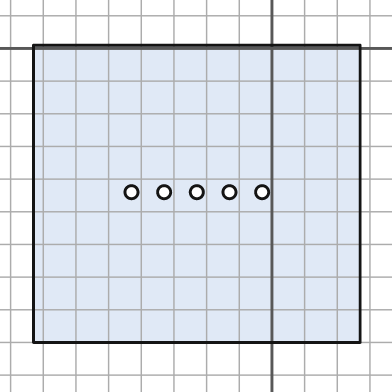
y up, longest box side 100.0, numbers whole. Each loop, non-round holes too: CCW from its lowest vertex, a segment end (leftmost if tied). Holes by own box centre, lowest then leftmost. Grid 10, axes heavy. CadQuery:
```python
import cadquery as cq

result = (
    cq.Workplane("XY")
    .moveTo(-73.0, -90.0)
    .lineTo(27.0, -90.0)
    .lineTo(27.0, 1.0)
    .lineTo(-73.0, 1.0)
    .close()
    .moveTo(-43.0, -44.0)
    .circle(2.0)
    .moveTo(-33.0, -44.0)
    .circle(2.0)
    .moveTo(-23.0, -44.0)
    .circle(2.0)
    .moveTo(-13.0, -44.0)
    .circle(2.0)
    .moveTo(-3.0, -44.0)
    .circle(2.0)
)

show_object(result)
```